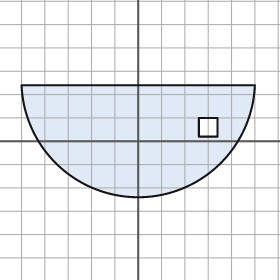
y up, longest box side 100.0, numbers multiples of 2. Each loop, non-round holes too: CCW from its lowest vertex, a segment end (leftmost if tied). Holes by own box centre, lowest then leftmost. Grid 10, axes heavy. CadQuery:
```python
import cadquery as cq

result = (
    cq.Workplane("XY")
    .moveTo(-50.0, 24.0)
    .threePointArc((0.0, -24.0), (50.0, 24.0))
    .close()
    .moveTo(26.0, 2.0)
    .lineTo(34.0, 2.0)
    .lineTo(34.0, 10.0)
    .lineTo(26.0, 10.0)
    .close()
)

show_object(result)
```